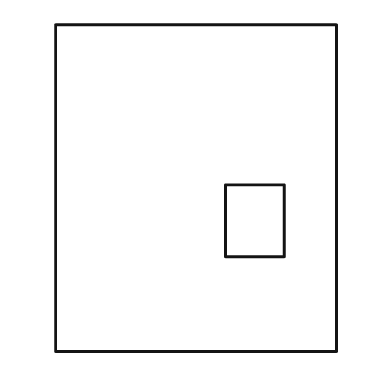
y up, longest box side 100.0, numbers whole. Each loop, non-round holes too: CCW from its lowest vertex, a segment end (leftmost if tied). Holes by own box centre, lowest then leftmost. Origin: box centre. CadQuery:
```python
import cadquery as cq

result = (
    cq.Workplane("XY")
    .moveTo(-43.0, -50.0)
    .lineTo(43.0, -50.0)
    .lineTo(43.0, 50.0)
    .lineTo(-43.0, 50.0)
    .close()
    .moveTo(9.0, -21.0)
    .lineTo(27.0, -21.0)
    .lineTo(27.0, 1.0)
    .lineTo(9.0, 1.0)
    .close()
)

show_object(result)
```